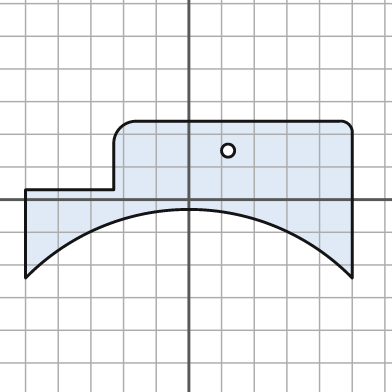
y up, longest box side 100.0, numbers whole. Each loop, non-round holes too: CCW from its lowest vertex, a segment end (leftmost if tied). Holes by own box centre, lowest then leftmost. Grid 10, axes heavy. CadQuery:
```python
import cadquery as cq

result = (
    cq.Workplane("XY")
    .moveTo(-50.0, -24.0)
    .threePointArc((0.0, -3.0), (50.0, -24.0))
    .lineTo(50.0, 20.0)
    .threePointArc((49.0, 23.0), (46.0, 24.0))
    .lineTo(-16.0, 24.0)
    .threePointArc((-21.0, 22.0), (-23.0, 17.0))
    .lineTo(-23.0, 3.0)
    .lineTo(-50.0, 3.0)
    .close()
    .moveTo(12.0, 15.0)
    .circle(2.0)
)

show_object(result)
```